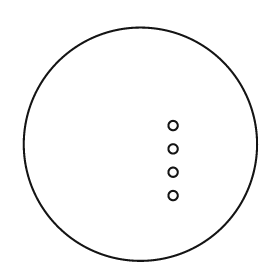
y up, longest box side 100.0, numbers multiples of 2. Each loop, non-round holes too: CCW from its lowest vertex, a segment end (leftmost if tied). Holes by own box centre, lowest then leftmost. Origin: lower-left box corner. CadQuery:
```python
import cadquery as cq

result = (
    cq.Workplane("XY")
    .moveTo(50.0, 50.0)
    .circle(50.0)
    .moveTo(64.0, 28.0)
    .circle(2.0)
    .moveTo(64.0, 38.0)
    .circle(2.0)
    .moveTo(64.0, 48.0)
    .circle(2.0)
    .moveTo(64.0, 58.0)
    .circle(2.0)
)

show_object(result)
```